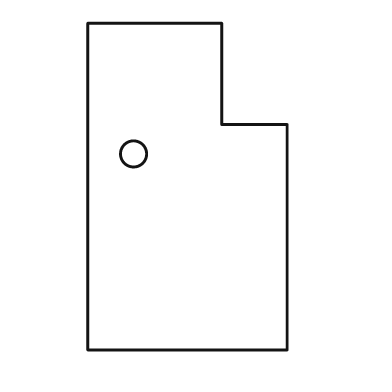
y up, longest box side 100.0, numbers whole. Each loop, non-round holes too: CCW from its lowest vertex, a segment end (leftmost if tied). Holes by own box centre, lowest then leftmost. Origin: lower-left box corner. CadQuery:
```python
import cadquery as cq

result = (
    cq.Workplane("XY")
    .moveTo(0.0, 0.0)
    .lineTo(61.0, 0.0)
    .lineTo(61.0, 69.0)
    .lineTo(41.0, 69.0)
    .lineTo(41.0, 100.0)
    .lineTo(0.0, 100.0)
    .close()
    .moveTo(14.0, 60.0)
    .circle(4.0)
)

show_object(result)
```